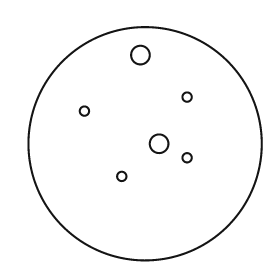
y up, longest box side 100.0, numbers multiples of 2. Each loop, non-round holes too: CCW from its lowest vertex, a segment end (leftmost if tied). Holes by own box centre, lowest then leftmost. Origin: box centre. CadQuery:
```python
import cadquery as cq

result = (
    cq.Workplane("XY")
    .moveTo(0.0, 0.0)
    .circle(50.0)
    .moveTo(-10.0, -14.0)
    .circle(2.0)
    .moveTo(18.0, -6.0)
    .circle(2.0)
    .moveTo(6.0, 0.0)
    .circle(4.0)
    .moveTo(-26.0, 14.0)
    .circle(2.0)
    .moveTo(18.0, 20.0)
    .circle(2.0)
    .moveTo(-2.0, 38.0)
    .circle(4.0)
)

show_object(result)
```